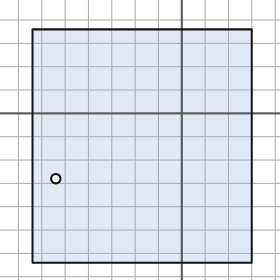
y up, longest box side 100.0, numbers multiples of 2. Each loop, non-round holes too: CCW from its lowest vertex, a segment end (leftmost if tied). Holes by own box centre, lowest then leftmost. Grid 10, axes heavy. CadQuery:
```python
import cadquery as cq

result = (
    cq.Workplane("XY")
    .moveTo(-64.0, -64.0)
    .lineTo(30.0, -64.0)
    .lineTo(30.0, 36.0)
    .lineTo(-64.0, 36.0)
    .close()
    .moveTo(-54.0, -28.0)
    .circle(2.0)
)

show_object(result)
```